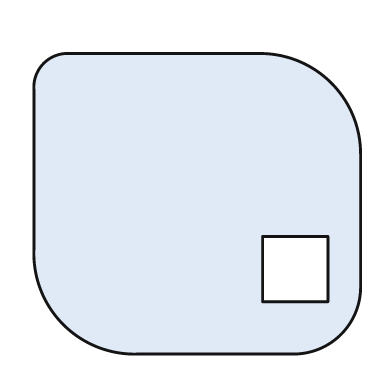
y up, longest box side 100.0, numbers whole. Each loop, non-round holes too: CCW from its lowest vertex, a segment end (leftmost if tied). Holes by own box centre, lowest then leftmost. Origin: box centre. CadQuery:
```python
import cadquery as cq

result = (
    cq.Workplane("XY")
    .moveTo(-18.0, -46.0)
    .lineTo(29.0, -46.0)
    .threePointArc((44.0, -40.0), (50.0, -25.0))
    .lineTo(50.0, 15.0)
    .threePointArc((41.0, 37.0), (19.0, 46.0))
    .lineTo(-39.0, 46.0)
    .threePointArc((-47.0, 43.0), (-50.0, 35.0))
    .lineTo(-50.0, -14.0)
    .threePointArc((-41.0, -37.0), (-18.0, -46.0))
    .close()
    .moveTo(20.0, -30.0)
    .lineTo(40.0, -30.0)
    .lineTo(40.0, -10.0)
    .lineTo(20.0, -10.0)
    .close()
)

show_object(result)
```